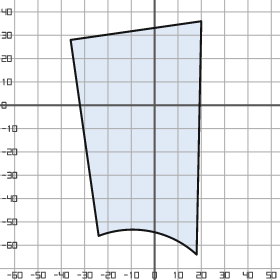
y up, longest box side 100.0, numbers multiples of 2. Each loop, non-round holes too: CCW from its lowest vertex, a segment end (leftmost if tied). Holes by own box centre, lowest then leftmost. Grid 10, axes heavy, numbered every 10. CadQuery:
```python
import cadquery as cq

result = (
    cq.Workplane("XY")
    .moveTo(18.0, -64.0)
    .lineTo(20.0, 36.0)
    .lineTo(-36.0, 28.0)
    .lineTo(-24.0, -56.0)
    .threePointArc((-2.0, -54.0), (18.0, -64.0))
    .close()
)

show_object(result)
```